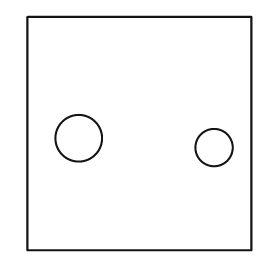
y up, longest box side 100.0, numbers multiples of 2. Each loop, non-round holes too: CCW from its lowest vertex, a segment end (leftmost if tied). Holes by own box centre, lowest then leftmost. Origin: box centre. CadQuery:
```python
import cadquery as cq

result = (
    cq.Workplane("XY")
    .moveTo(-48.0, -50.0)
    .lineTo(48.0, -50.0)
    .lineTo(48.0, 50.0)
    .lineTo(-48.0, 50.0)
    .close()
    .moveTo(32.0, -6.0)
    .circle(8.0)
    .moveTo(-26.0, -2.0)
    .circle(10.0)
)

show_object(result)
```